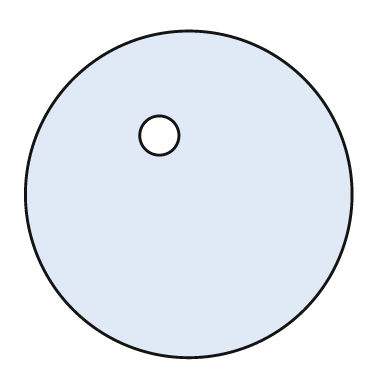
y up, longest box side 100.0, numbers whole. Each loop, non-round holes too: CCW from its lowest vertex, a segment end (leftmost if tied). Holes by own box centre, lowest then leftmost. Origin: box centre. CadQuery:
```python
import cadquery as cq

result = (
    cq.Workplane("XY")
    .moveTo(0.0, 0.0)
    .circle(50.0)
    .moveTo(-9.0, 18.0)
    .circle(6.0)
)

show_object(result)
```